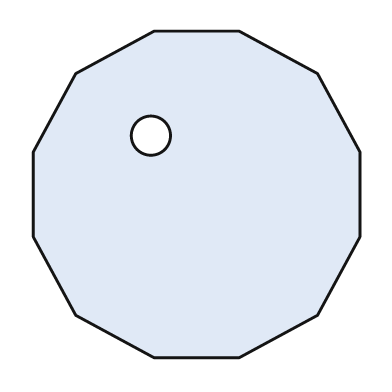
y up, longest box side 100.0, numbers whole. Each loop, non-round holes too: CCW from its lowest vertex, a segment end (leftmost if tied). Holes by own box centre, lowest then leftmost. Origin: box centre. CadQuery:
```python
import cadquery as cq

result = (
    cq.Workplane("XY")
    .moveTo(-13.0, -50.0)
    .lineTo(13.0, -50.0)
    .lineTo(37.0, -37.0)
    .lineTo(50.0, -13.0)
    .lineTo(50.0, 13.0)
    .lineTo(37.0, 37.0)
    .lineTo(13.0, 50.0)
    .lineTo(-13.0, 50.0)
    .lineTo(-37.0, 37.0)
    .lineTo(-50.0, 13.0)
    .lineTo(-50.0, -13.0)
    .lineTo(-37.0, -37.0)
    .close()
    .moveTo(-14.0, 18.0)
    .circle(6.0)
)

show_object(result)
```